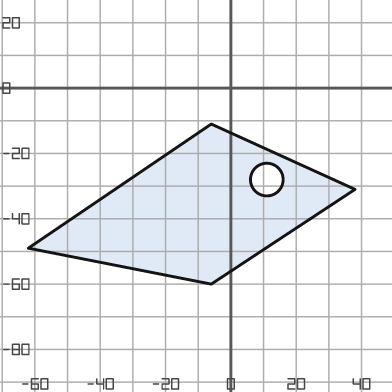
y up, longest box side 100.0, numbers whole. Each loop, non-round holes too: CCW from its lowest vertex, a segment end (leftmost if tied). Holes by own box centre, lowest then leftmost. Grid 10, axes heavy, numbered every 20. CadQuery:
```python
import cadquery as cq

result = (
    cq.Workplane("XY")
    .moveTo(-6.0, -60.0)
    .lineTo(38.0, -31.0)
    .lineTo(-6.0, -11.0)
    .lineTo(-62.0, -49.0)
    .close()
    .moveTo(11.0, -28.0)
    .circle(5.0)
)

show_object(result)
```